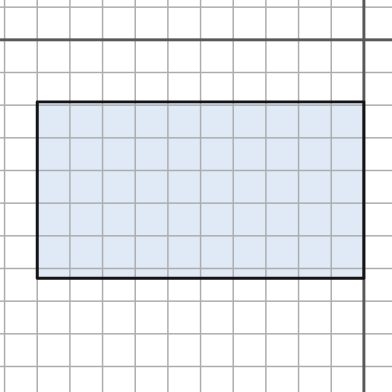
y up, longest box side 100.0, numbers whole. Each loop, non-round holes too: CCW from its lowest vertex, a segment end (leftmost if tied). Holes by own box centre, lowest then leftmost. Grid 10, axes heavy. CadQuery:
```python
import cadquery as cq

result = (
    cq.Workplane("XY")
    .moveTo(-100.0, -73.0)
    .lineTo(0.0, -73.0)
    .lineTo(0.0, -19.0)
    .lineTo(-100.0, -19.0)
    .close()
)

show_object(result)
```